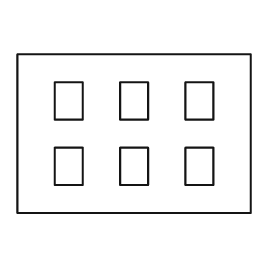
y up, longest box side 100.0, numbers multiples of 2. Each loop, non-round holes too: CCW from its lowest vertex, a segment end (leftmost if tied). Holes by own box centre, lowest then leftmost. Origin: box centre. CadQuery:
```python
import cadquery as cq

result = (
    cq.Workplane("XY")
    .moveTo(-50.0, -34.0)
    .lineTo(50.0, -34.0)
    .lineTo(50.0, 34.0)
    .lineTo(-50.0, 34.0)
    .close()
    .moveTo(-34.0, -22.0)
    .lineTo(-22.0, -22.0)
    .lineTo(-22.0, -6.0)
    .lineTo(-34.0, -6.0)
    .close()
    .moveTo(-6.0, -22.0)
    .lineTo(6.0, -22.0)
    .lineTo(6.0, -6.0)
    .lineTo(-6.0, -6.0)
    .close()
    .moveTo(22.0, -22.0)
    .lineTo(34.0, -22.0)
    .lineTo(34.0, -6.0)
    .lineTo(22.0, -6.0)
    .close()
    .moveTo(-34.0, 6.0)
    .lineTo(-22.0, 6.0)
    .lineTo(-22.0, 22.0)
    .lineTo(-34.0, 22.0)
    .close()
    .moveTo(-6.0, 6.0)
    .lineTo(6.0, 6.0)
    .lineTo(6.0, 22.0)
    .lineTo(-6.0, 22.0)
    .close()
    .moveTo(22.0, 6.0)
    .lineTo(34.0, 6.0)
    .lineTo(34.0, 22.0)
    .lineTo(22.0, 22.0)
    .close()
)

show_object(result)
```